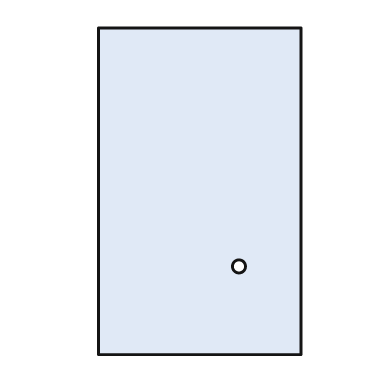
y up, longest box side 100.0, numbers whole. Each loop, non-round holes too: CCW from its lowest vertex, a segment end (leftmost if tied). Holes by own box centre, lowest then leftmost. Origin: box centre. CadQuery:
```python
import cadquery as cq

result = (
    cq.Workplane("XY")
    .moveTo(-31.0, -50.0)
    .lineTo(31.0, -50.0)
    .lineTo(31.0, 50.0)
    .lineTo(-31.0, 50.0)
    .close()
    .moveTo(12.0, -23.0)
    .circle(2.0)
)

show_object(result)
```